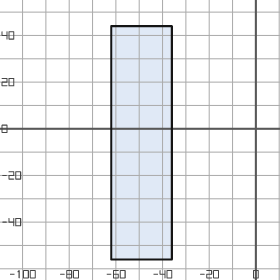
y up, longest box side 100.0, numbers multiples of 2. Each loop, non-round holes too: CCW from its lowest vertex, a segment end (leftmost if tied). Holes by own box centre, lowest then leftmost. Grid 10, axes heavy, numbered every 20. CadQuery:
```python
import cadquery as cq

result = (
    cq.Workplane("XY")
    .moveTo(-62.0, -56.0)
    .lineTo(-36.0, -56.0)
    .lineTo(-36.0, 44.0)
    .lineTo(-62.0, 44.0)
    .close()
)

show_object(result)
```